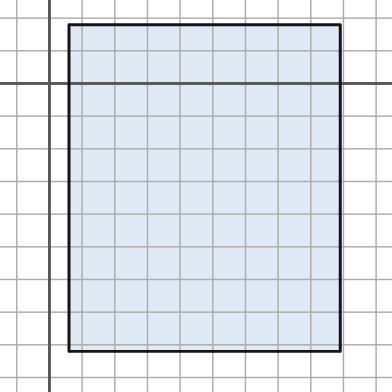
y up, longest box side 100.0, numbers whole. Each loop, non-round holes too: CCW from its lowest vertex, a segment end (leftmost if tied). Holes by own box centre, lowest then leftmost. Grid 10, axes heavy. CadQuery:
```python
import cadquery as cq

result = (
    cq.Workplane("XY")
    .moveTo(6.0, -82.0)
    .lineTo(89.0, -82.0)
    .lineTo(89.0, 18.0)
    .lineTo(6.0, 18.0)
    .close()
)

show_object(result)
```